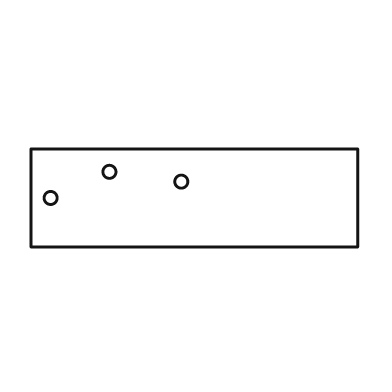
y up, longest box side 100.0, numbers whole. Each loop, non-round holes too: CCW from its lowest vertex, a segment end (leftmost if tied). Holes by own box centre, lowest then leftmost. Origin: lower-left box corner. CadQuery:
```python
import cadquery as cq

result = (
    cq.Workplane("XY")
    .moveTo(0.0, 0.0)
    .lineTo(100.0, 0.0)
    .lineTo(100.0, 30.0)
    .lineTo(0.0, 30.0)
    .close()
    .moveTo(6.0, 15.0)
    .circle(2.0)
    .moveTo(46.0, 20.0)
    .circle(2.0)
    .moveTo(24.0, 23.0)
    .circle(2.0)
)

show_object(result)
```